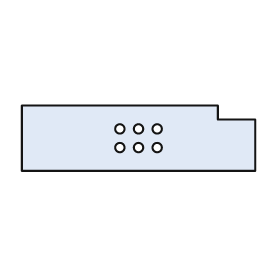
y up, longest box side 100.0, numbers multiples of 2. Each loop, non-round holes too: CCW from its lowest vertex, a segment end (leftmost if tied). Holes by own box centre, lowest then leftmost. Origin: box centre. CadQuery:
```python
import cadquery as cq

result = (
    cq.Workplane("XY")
    .moveTo(-50.0, -14.0)
    .lineTo(50.0, -14.0)
    .lineTo(50.0, 8.0)
    .lineTo(34.0, 8.0)
    .lineTo(34.0, 14.0)
    .lineTo(-50.0, 14.0)
    .close()
    .moveTo(-8.0, -4.0)
    .circle(2.0)
    .moveTo(0.0, -4.0)
    .circle(2.0)
    .moveTo(8.0, -4.0)
    .circle(2.0)
    .moveTo(-8.0, 4.0)
    .circle(2.0)
    .moveTo(0.0, 4.0)
    .circle(2.0)
    .moveTo(8.0, 4.0)
    .circle(2.0)
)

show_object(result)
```